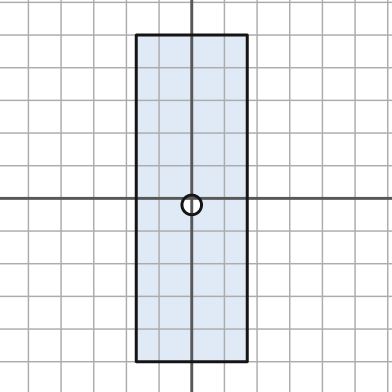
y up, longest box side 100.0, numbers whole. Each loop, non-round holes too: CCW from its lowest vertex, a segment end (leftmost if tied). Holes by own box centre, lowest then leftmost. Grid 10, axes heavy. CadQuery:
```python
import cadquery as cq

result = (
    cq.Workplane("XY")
    .moveTo(-17.0, -50.0)
    .lineTo(17.0, -50.0)
    .lineTo(17.0, 50.0)
    .lineTo(-17.0, 50.0)
    .close()
    .moveTo(0.0, -2.0)
    .circle(3.0)
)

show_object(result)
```